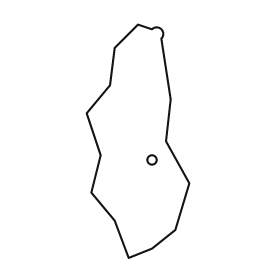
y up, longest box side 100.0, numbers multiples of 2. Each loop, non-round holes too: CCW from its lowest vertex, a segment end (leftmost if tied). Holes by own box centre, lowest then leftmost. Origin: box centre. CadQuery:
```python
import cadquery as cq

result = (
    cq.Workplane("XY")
    .moveTo(-4.0, -50.0)
    .lineTo(6.0, -46.0)
    .lineTo(16.0, -38.0)
    .lineTo(22.0, -18.0)
    .lineTo(12.0, 0.0)
    .lineTo(14.0, 18.0)
    .lineTo(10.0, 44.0)
    .threePointArc((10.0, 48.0), (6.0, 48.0))
    .lineTo(0.0, 50.0)
    .lineTo(-10.0, 40.0)
    .lineTo(-12.0, 24.0)
    .lineTo(-22.0, 12.0)
    .lineTo(-16.0, -6.0)
    .lineTo(-20.0, -22.0)
    .lineTo(-10.0, -34.0)
    .close()
    .moveTo(6.0, -8.0)
    .circle(2.0)
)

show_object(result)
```